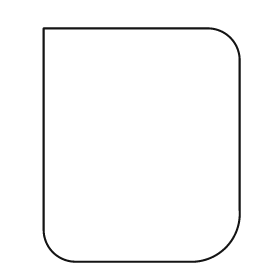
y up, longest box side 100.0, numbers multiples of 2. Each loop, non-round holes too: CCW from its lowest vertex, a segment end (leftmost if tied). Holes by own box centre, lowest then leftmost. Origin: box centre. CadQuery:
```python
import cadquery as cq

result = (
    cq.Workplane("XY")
    .moveTo(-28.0, -50.0)
    .lineTo(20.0, -50.0)
    .threePointArc((36.0, -44.0), (42.0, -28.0))
    .lineTo(42.0, 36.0)
    .threePointArc((38.0, 46.0), (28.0, 50.0))
    .lineTo(-42.0, 50.0)
    .lineTo(-42.0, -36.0)
    .threePointArc((-38.0, -46.0), (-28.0, -50.0))
    .close()
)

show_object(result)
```